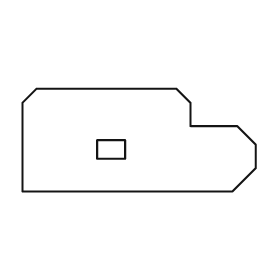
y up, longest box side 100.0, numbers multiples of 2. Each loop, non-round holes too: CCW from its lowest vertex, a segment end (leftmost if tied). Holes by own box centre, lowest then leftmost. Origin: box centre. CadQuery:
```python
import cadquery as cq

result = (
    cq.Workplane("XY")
    .moveTo(-50.0, -22.0)
    .lineTo(40.0, -22.0)
    .lineTo(50.0, -12.0)
    .lineTo(50.0, -2.0)
    .lineTo(42.0, 6.0)
    .lineTo(22.0, 6.0)
    .lineTo(22.0, 16.0)
    .lineTo(16.0, 22.0)
    .lineTo(-44.0, 22.0)
    .lineTo(-50.0, 16.0)
    .close()
    .moveTo(-18.0, -8.0)
    .lineTo(-6.0, -8.0)
    .lineTo(-6.0, 0.0)
    .lineTo(-18.0, 0.0)
    .close()
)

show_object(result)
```